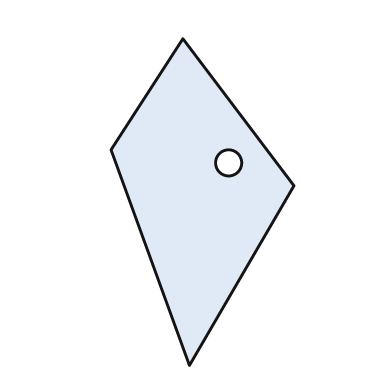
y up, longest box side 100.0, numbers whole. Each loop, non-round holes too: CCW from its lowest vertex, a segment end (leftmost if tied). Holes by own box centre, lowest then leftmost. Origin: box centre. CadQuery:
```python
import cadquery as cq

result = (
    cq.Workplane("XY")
    .moveTo(-4.0, -50.0)
    .lineTo(28.0, 5.0)
    .lineTo(-6.0, 50.0)
    .lineTo(-28.0, 16.0)
    .close()
    .moveTo(8.0, 12.0)
    .circle(4.0)
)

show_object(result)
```